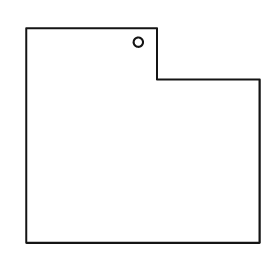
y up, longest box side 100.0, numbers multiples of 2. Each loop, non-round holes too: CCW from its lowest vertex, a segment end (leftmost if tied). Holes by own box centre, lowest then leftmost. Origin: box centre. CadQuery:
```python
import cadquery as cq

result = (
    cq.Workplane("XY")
    .moveTo(-50.0, -46.0)
    .lineTo(50.0, -46.0)
    .lineTo(50.0, 24.0)
    .lineTo(6.0, 24.0)
    .lineTo(6.0, 46.0)
    .lineTo(-50.0, 46.0)
    .close()
    .moveTo(-2.0, 40.0)
    .circle(2.0)
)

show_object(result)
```